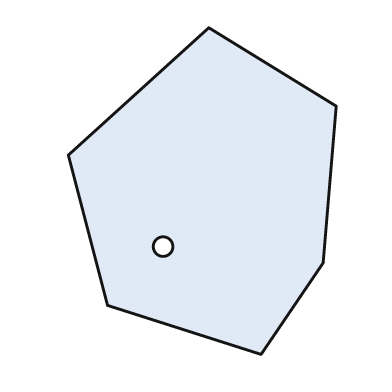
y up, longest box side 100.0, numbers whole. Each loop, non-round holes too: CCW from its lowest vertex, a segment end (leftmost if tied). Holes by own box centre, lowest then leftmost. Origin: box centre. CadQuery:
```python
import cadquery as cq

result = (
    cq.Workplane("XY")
    .moveTo(18.0, -50.0)
    .lineTo(37.0, -22.0)
    .lineTo(41.0, 26.0)
    .lineTo(2.0, 50.0)
    .lineTo(-41.0, 11.0)
    .lineTo(-29.0, -35.0)
    .close()
    .moveTo(-12.0, -17.0)
    .circle(3.0)
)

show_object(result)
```